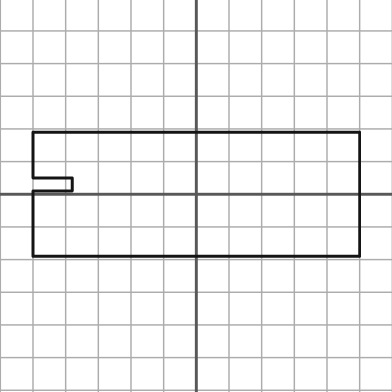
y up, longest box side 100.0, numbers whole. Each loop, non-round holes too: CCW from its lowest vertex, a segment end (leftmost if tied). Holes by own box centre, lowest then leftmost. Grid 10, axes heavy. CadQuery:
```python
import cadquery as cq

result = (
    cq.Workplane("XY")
    .moveTo(-50.0, -19.0)
    .lineTo(50.0, -19.0)
    .lineTo(50.0, 19.0)
    .lineTo(-50.0, 19.0)
    .lineTo(-50.0, 5.0)
    .lineTo(-38.0, 5.0)
    .lineTo(-38.0, 1.0)
    .lineTo(-50.0, 1.0)
    .close()
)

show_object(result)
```